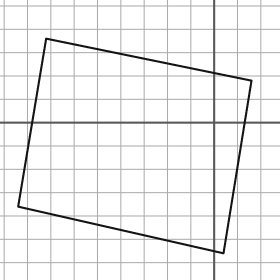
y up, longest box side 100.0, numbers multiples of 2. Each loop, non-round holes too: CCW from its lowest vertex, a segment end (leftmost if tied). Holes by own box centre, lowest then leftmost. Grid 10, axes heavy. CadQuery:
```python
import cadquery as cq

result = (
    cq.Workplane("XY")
    .moveTo(4.0, -56.0)
    .lineTo(16.0, 18.0)
    .lineTo(-72.0, 36.0)
    .lineTo(-84.0, -36.0)
    .close()
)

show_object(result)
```